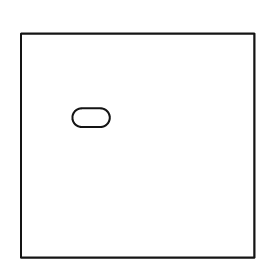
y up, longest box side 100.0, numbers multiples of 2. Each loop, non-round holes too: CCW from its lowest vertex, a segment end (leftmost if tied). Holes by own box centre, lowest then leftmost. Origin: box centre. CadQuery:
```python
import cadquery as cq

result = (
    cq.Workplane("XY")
    .moveTo(-50.0, -48.0)
    .lineTo(50.0, -48.0)
    .lineTo(50.0, 48.0)
    .lineTo(-50.0, 48.0)
    .close()
    .moveTo(-24.0, 8.0)
    .lineTo(-16.0, 8.0)
    .threePointArc((-12.0, 12.0), (-16.0, 16.0))
    .lineTo(-24.0, 16.0)
    .threePointArc((-28.0, 12.0), (-24.0, 8.0))
    .close()
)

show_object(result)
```